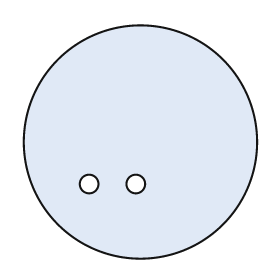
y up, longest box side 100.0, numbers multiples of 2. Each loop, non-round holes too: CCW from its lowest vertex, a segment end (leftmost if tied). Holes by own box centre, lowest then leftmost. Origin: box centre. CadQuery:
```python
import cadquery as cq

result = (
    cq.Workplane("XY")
    .moveTo(0.0, 0.0)
    .circle(50.0)
    .moveTo(-22.0, -18.0)
    .circle(4.0)
    .moveTo(-2.0, -18.0)
    .circle(4.0)
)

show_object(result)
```